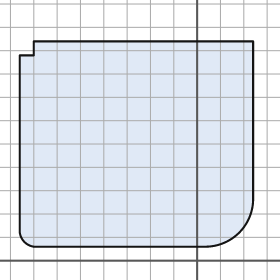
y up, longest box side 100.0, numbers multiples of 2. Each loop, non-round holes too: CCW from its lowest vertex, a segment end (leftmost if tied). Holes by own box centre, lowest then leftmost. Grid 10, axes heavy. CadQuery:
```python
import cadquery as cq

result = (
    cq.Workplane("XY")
    .moveTo(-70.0, 6.0)
    .lineTo(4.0, 6.0)
    .threePointArc((18.0, 12.0), (24.0, 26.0))
    .lineTo(24.0, 94.0)
    .lineTo(-70.0, 94.0)
    .lineTo(-70.0, 88.0)
    .lineTo(-76.0, 88.0)
    .lineTo(-76.0, 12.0)
    .threePointArc((-74.0, 8.0), (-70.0, 6.0))
    .close()
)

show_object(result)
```